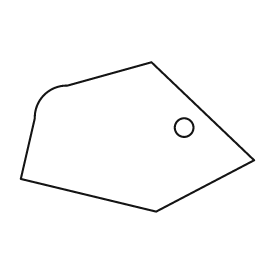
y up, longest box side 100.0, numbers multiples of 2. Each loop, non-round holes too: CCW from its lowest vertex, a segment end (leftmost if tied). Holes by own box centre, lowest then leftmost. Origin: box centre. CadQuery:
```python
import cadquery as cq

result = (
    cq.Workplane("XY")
    .moveTo(8.0, -32.0)
    .lineTo(50.0, -10.0)
    .lineTo(6.0, 32.0)
    .lineTo(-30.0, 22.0)
    .threePointArc((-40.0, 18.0), (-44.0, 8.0))
    .lineTo(-50.0, -18.0)
    .close()
    .moveTo(20.0, 4.0)
    .circle(4.0)
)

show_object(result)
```